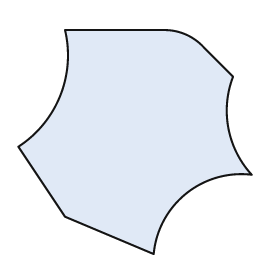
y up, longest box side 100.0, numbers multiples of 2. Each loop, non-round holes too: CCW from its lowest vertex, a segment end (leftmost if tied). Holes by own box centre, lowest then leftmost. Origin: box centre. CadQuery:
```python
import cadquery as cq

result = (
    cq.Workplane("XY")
    .moveTo(8.0, -48.0)
    .threePointArc((22.0, -22.0), (50.0, -14.0))
    .threePointArc((40.0, 6.0), (42.0, 28.0))
    .lineTo(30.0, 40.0)
    .threePointArc((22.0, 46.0), (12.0, 48.0))
    .lineTo(-30.0, 48.0)
    .threePointArc((-32.0, 20.0), (-50.0, -2.0))
    .lineTo(-30.0, -32.0)
    .close()
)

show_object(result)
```